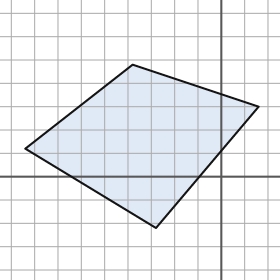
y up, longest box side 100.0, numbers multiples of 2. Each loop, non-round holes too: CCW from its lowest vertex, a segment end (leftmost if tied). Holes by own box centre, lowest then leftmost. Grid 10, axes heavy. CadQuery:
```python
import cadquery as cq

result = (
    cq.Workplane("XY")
    .moveTo(-28.0, -22.0)
    .lineTo(16.0, 30.0)
    .lineTo(-38.0, 48.0)
    .lineTo(-84.0, 12.0)
    .close()
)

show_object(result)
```